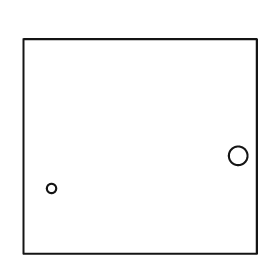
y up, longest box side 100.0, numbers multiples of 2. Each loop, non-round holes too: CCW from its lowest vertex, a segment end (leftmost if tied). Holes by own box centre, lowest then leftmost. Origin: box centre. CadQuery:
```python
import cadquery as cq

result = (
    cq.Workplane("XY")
    .moveTo(-50.0, -46.0)
    .lineTo(50.0, -46.0)
    .lineTo(50.0, 46.0)
    .lineTo(-50.0, 46.0)
    .close()
    .moveTo(-38.0, -18.0)
    .circle(2.0)
    .moveTo(42.0, -4.0)
    .circle(4.0)
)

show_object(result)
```